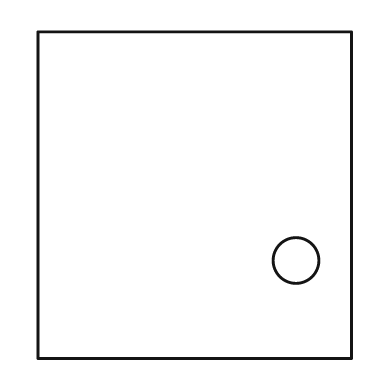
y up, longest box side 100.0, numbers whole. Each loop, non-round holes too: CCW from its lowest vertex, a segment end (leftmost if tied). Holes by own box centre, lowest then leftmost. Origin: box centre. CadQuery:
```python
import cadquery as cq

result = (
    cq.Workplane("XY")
    .moveTo(-48.0, -50.0)
    .lineTo(48.0, -50.0)
    .lineTo(48.0, 50.0)
    .lineTo(-48.0, 50.0)
    .close()
    .moveTo(31.0, -20.0)
    .circle(7.0)
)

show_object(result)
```